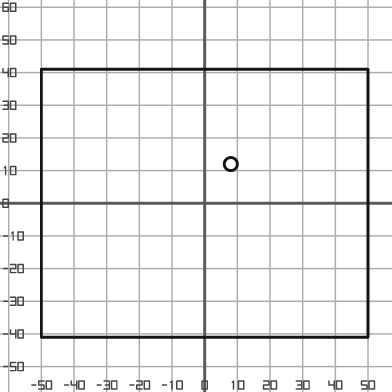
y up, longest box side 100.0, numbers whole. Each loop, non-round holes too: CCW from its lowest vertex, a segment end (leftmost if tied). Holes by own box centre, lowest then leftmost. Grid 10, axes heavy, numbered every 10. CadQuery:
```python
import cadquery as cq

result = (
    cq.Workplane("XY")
    .moveTo(-50.0, -41.0)
    .lineTo(50.0, -41.0)
    .lineTo(50.0, 41.0)
    .lineTo(-50.0, 41.0)
    .close()
    .moveTo(8.0, 12.0)
    .circle(2.0)
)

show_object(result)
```